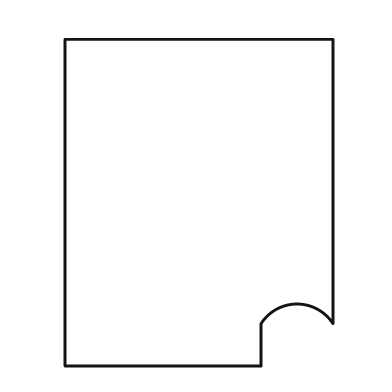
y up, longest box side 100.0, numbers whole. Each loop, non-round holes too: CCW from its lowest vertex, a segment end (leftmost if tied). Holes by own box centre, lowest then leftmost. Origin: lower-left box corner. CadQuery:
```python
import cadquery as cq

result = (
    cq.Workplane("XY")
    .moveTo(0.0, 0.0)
    .lineTo(60.0, 0.0)
    .lineTo(60.0, 13.0)
    .threePointArc((71.0, 19.0), (82.0, 13.0))
    .lineTo(82.0, 100.0)
    .lineTo(0.0, 100.0)
    .close()
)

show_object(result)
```